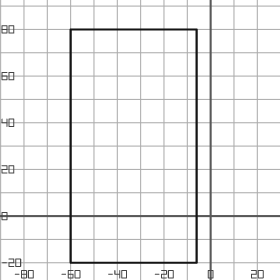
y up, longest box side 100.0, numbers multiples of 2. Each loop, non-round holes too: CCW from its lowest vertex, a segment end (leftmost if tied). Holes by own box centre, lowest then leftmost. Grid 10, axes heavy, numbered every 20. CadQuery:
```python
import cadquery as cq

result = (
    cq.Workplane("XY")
    .moveTo(-60.0, -20.0)
    .lineTo(-6.0, -20.0)
    .lineTo(-6.0, 80.0)
    .lineTo(-60.0, 80.0)
    .close()
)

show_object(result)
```